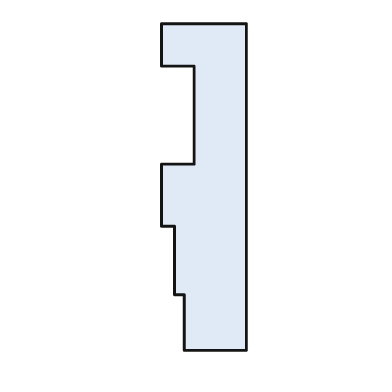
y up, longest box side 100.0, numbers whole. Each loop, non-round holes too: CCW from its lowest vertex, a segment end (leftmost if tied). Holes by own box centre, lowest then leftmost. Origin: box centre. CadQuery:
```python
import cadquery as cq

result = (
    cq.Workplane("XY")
    .moveTo(-6.0, -50.0)
    .lineTo(13.0, -50.0)
    .lineTo(13.0, 50.0)
    .lineTo(-13.0, 50.0)
    .lineTo(-13.0, 37.0)
    .lineTo(-3.0, 37.0)
    .lineTo(-3.0, 7.0)
    .lineTo(-13.0, 7.0)
    .lineTo(-13.0, -12.0)
    .lineTo(-9.0, -12.0)
    .lineTo(-9.0, -33.0)
    .lineTo(-6.0, -33.0)
    .close()
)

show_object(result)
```